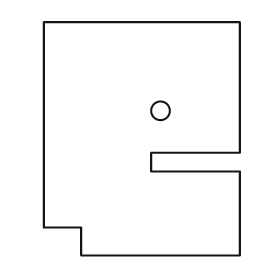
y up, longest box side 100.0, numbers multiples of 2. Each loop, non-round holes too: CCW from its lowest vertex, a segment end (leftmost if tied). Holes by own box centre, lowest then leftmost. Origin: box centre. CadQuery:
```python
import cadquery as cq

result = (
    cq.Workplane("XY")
    .moveTo(-26.0, -50.0)
    .lineTo(42.0, -50.0)
    .lineTo(42.0, -14.0)
    .lineTo(4.0, -14.0)
    .lineTo(4.0, -6.0)
    .lineTo(42.0, -6.0)
    .lineTo(42.0, 50.0)
    .lineTo(-42.0, 50.0)
    .lineTo(-42.0, -38.0)
    .lineTo(-26.0, -38.0)
    .close()
    .moveTo(8.0, 12.0)
    .circle(4.0)
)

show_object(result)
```